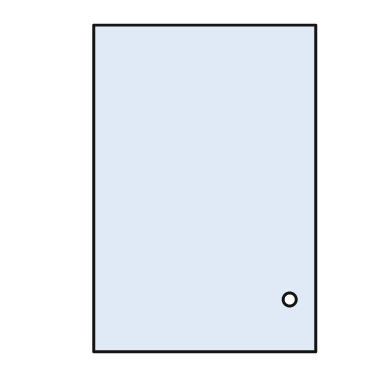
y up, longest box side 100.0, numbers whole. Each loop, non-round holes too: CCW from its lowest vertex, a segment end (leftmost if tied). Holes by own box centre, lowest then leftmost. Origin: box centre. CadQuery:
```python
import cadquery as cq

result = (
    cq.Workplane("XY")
    .moveTo(-34.0, -50.0)
    .lineTo(34.0, -50.0)
    .lineTo(34.0, 50.0)
    .lineTo(-34.0, 50.0)
    .close()
    .moveTo(26.0, -34.0)
    .circle(2.0)
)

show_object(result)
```